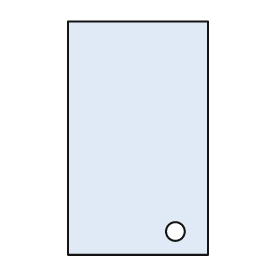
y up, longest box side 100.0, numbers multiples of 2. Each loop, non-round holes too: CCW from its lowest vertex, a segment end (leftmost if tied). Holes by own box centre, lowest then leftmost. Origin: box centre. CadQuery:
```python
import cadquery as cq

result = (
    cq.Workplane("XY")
    .moveTo(-30.0, -50.0)
    .lineTo(30.0, -50.0)
    .lineTo(30.0, 50.0)
    .lineTo(-30.0, 50.0)
    .close()
    .moveTo(16.0, -40.0)
    .circle(4.0)
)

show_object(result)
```